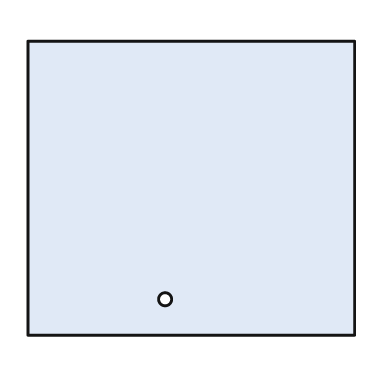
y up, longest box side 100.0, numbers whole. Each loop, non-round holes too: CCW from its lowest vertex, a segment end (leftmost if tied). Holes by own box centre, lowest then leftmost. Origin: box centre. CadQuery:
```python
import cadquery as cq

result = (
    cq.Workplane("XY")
    .moveTo(-50.0, -45.0)
    .lineTo(50.0, -45.0)
    .lineTo(50.0, 45.0)
    .lineTo(-50.0, 45.0)
    .close()
    .moveTo(-8.0, -34.0)
    .circle(2.0)
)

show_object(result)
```